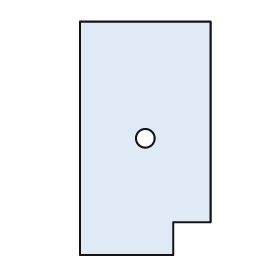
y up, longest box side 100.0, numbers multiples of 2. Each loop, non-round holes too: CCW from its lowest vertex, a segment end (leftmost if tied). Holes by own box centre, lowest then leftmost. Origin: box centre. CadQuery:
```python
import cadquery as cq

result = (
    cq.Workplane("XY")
    .moveTo(-28.0, -50.0)
    .lineTo(12.0, -50.0)
    .lineTo(12.0, -36.0)
    .lineTo(28.0, -36.0)
    .lineTo(28.0, 50.0)
    .lineTo(-28.0, 50.0)
    .close()
    .moveTo(0.0, 0.0)
    .circle(4.0)
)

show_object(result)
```